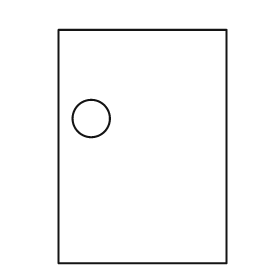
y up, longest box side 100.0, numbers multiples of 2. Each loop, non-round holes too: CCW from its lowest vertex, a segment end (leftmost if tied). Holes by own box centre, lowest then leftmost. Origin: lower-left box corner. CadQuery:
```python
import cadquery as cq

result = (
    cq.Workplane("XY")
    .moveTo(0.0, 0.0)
    .lineTo(72.0, 0.0)
    .lineTo(72.0, 100.0)
    .lineTo(0.0, 100.0)
    .close()
    .moveTo(14.0, 62.0)
    .circle(8.0)
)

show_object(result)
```